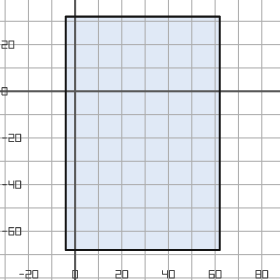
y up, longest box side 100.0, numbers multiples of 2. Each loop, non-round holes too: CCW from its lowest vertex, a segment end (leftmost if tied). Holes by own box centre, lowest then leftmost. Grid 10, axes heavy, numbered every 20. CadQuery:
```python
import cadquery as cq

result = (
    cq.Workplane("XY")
    .moveTo(-4.0, -68.0)
    .lineTo(62.0, -68.0)
    .lineTo(62.0, 32.0)
    .lineTo(-4.0, 32.0)
    .close()
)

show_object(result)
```